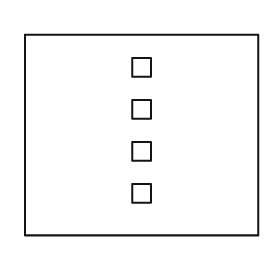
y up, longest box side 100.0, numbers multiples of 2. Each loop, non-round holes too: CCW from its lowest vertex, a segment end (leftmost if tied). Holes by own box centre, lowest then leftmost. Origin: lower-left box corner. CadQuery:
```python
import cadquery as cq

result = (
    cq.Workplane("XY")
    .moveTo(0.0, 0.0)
    .lineTo(100.0, 0.0)
    .lineTo(100.0, 86.0)
    .lineTo(0.0, 86.0)
    .close()
    .moveTo(46.0, 14.0)
    .lineTo(54.0, 14.0)
    .lineTo(54.0, 22.0)
    .lineTo(46.0, 22.0)
    .close()
    .moveTo(46.0, 32.0)
    .lineTo(54.0, 32.0)
    .lineTo(54.0, 40.0)
    .lineTo(46.0, 40.0)
    .close()
    .moveTo(46.0, 50.0)
    .lineTo(54.0, 50.0)
    .lineTo(54.0, 58.0)
    .lineTo(46.0, 58.0)
    .close()
    .moveTo(46.0, 68.0)
    .lineTo(54.0, 68.0)
    .lineTo(54.0, 76.0)
    .lineTo(46.0, 76.0)
    .close()
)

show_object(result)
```